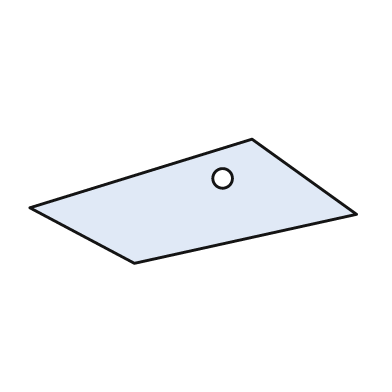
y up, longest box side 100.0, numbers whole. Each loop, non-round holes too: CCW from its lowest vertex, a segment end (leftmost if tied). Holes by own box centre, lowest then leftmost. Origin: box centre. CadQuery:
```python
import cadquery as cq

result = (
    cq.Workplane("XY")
    .moveTo(-18.0, -19.0)
    .lineTo(50.0, -4.0)
    .lineTo(18.0, 19.0)
    .lineTo(-50.0, -2.0)
    .close()
    .moveTo(9.0, 7.0)
    .circle(3.0)
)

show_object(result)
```